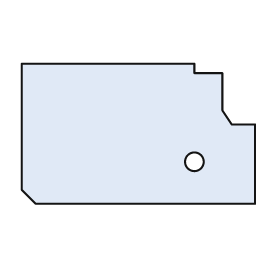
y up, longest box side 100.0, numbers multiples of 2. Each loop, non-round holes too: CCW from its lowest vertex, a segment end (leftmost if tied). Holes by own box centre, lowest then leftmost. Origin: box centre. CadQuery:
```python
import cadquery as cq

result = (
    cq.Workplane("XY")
    .moveTo(-44.0, -30.0)
    .lineTo(50.0, -30.0)
    .lineTo(50.0, 4.0)
    .lineTo(40.0, 4.0)
    .lineTo(36.0, 10.0)
    .lineTo(36.0, 26.0)
    .lineTo(24.0, 26.0)
    .lineTo(24.0, 30.0)
    .lineTo(-50.0, 30.0)
    .lineTo(-50.0, -24.0)
    .close()
    .moveTo(24.0, -12.0)
    .circle(4.0)
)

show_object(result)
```